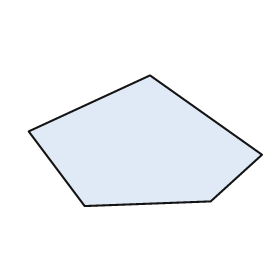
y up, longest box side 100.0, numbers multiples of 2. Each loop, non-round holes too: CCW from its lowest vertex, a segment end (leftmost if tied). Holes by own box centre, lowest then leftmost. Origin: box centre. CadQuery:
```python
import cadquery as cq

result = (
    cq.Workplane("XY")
    .moveTo(-26.0, -28.0)
    .lineTo(28.0, -26.0)
    .lineTo(50.0, -6.0)
    .lineTo(2.0, 28.0)
    .lineTo(-50.0, 4.0)
    .close()
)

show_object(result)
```